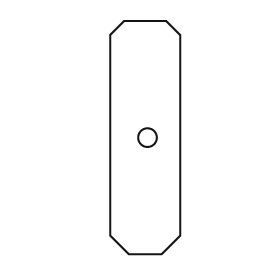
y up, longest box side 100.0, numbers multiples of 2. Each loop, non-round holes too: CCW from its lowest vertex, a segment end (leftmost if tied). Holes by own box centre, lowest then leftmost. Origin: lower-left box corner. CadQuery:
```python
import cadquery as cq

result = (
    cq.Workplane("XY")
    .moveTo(8.0, 0.0)
    .lineTo(22.0, 0.0)
    .lineTo(30.0, 8.0)
    .lineTo(30.0, 94.0)
    .lineTo(24.0, 100.0)
    .lineTo(6.0, 100.0)
    .lineTo(0.0, 94.0)
    .lineTo(0.0, 8.0)
    .close()
    .moveTo(16.0, 50.0)
    .circle(4.0)
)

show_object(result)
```